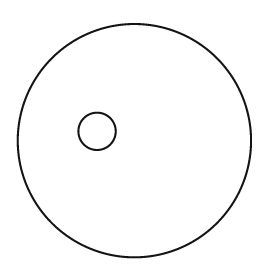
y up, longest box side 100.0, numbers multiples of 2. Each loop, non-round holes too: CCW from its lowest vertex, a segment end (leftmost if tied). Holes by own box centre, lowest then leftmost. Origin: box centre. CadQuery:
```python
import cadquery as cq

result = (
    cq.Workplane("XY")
    .moveTo(0.0, 0.0)
    .circle(50.0)
    .moveTo(-16.0, 4.0)
    .circle(8.0)
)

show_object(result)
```